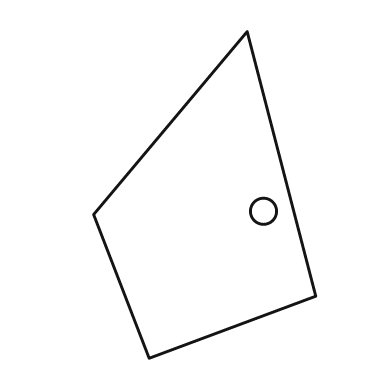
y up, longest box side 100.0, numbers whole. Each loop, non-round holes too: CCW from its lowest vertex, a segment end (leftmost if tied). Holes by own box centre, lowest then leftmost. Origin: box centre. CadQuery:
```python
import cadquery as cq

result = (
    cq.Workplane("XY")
    .moveTo(-17.0, -50.0)
    .lineTo(34.0, -31.0)
    .lineTo(13.0, 50.0)
    .lineTo(-34.0, -6.0)
    .close()
    .moveTo(18.0, -5.0)
    .circle(4.0)
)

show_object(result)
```